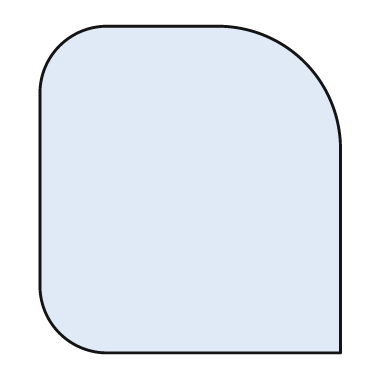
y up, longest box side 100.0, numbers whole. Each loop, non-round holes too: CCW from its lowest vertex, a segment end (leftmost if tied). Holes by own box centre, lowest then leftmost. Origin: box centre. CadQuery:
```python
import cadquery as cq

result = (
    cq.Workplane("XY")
    .moveTo(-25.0, -50.0)
    .lineTo(46.0, -50.0)
    .lineTo(46.0, 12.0)
    .threePointArc((35.0, 39.0), (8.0, 50.0))
    .lineTo(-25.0, 50.0)
    .threePointArc((-40.0, 44.0), (-46.0, 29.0))
    .lineTo(-46.0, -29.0)
    .threePointArc((-40.0, -44.0), (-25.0, -50.0))
    .close()
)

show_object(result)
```